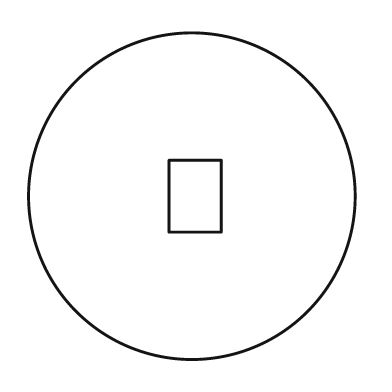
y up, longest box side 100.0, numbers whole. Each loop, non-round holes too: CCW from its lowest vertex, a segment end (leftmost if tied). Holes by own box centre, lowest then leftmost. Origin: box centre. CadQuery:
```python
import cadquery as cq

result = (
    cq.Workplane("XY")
    .moveTo(0.0, 0.0)
    .circle(50.0)
    .moveTo(-7.0, -11.0)
    .lineTo(9.0, -11.0)
    .lineTo(9.0, 11.0)
    .lineTo(-7.0, 11.0)
    .close()
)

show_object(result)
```